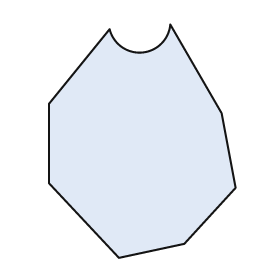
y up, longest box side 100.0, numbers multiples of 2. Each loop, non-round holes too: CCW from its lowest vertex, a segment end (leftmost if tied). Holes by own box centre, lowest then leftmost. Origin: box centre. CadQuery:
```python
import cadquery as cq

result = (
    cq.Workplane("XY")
    .moveTo(-10.0, -50.0)
    .lineTo(18.0, -44.0)
    .lineTo(40.0, -20.0)
    .lineTo(34.0, 12.0)
    .lineTo(12.0, 50.0)
    .threePointArc((0.0, 38.0), (-14.0, 48.0))
    .lineTo(-40.0, 16.0)
    .lineTo(-40.0, -18.0)
    .close()
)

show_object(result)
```